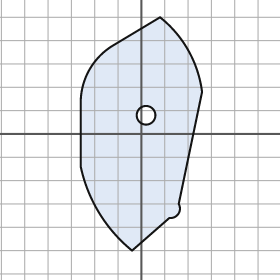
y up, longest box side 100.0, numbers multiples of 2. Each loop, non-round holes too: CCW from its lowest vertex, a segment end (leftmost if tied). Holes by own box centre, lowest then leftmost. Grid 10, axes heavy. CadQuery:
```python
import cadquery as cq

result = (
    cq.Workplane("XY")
    .moveTo(-4.0, -50.0)
    .lineTo(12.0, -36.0)
    .threePointArc((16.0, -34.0), (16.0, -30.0))
    .lineTo(26.0, 18.0)
    .threePointArc((20.0, 36.0), (8.0, 50.0))
    .lineTo(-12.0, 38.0)
    .threePointArc((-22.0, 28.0), (-26.0, 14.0))
    .lineTo(-26.0, -14.0)
    .threePointArc((-18.0, -34.0), (-4.0, -50.0))
    .close()
    .moveTo(2.0, 8.0)
    .circle(4.0)
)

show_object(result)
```